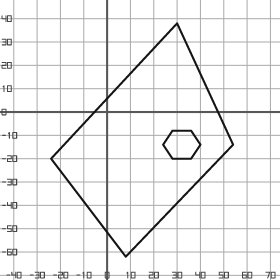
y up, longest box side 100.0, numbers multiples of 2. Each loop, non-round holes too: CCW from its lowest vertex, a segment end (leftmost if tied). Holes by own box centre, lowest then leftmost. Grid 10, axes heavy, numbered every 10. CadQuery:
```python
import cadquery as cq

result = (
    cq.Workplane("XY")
    .moveTo(8.0, -62.0)
    .lineTo(54.0, -14.0)
    .lineTo(30.0, 38.0)
    .lineTo(-24.0, -20.0)
    .close()
    .moveTo(28.0, -20.0)
    .lineTo(36.0, -20.0)
    .lineTo(40.0, -14.0)
    .lineTo(36.0, -8.0)
    .lineTo(28.0, -8.0)
    .lineTo(24.0, -14.0)
    .close()
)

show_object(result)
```